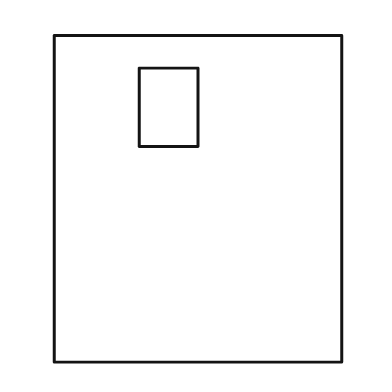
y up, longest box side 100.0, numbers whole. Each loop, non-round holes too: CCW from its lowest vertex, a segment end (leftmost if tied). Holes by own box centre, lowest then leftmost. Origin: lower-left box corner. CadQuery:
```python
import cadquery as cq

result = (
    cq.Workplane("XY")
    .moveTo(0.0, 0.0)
    .lineTo(88.0, 0.0)
    .lineTo(88.0, 100.0)
    .lineTo(0.0, 100.0)
    .close()
    .moveTo(26.0, 66.0)
    .lineTo(44.0, 66.0)
    .lineTo(44.0, 90.0)
    .lineTo(26.0, 90.0)
    .close()
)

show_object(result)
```